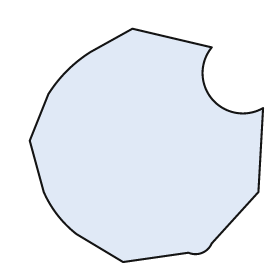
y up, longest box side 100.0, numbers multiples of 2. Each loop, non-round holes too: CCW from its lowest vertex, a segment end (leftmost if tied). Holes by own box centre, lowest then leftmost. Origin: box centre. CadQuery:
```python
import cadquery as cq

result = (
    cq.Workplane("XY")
    .moveTo(-10.0, -50.0)
    .lineTo(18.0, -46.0)
    .threePointArc((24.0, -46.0), (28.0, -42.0))
    .lineTo(48.0, -20.0)
    .lineTo(50.0, 16.0)
    .threePointArc((28.0, 20.0), (28.0, 42.0))
    .lineTo(-6.0, 50.0)
    .lineTo(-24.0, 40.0)
    .threePointArc((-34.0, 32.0), (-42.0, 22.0))
    .lineTo(-50.0, 2.0)
    .lineTo(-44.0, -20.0)
    .threePointArc((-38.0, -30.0), (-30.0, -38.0))
    .close()
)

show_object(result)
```